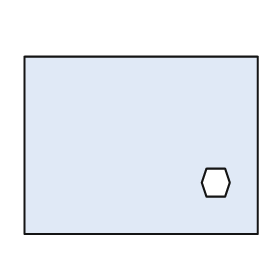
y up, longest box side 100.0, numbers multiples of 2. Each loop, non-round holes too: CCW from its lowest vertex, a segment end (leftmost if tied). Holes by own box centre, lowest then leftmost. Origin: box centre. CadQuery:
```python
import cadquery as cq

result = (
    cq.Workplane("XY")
    .moveTo(-50.0, -38.0)
    .lineTo(50.0, -38.0)
    .lineTo(50.0, 38.0)
    .lineTo(-50.0, 38.0)
    .close()
    .moveTo(28.0, -22.0)
    .lineTo(36.0, -22.0)
    .lineTo(38.0, -16.0)
    .lineTo(36.0, -10.0)
    .lineTo(28.0, -10.0)
    .lineTo(26.0, -16.0)
    .close()
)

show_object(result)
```